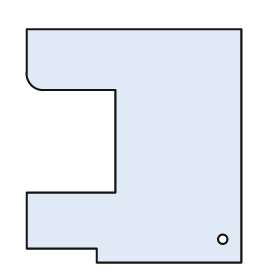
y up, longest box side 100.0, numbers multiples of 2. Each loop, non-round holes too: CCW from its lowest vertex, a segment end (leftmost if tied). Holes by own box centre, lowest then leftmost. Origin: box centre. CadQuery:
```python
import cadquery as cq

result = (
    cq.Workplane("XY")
    .moveTo(-16.0, -50.0)
    .lineTo(46.0, -50.0)
    .lineTo(46.0, 50.0)
    .lineTo(-46.0, 50.0)
    .lineTo(-46.0, 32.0)
    .threePointArc((-44.0, 26.0), (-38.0, 24.0))
    .lineTo(-8.0, 24.0)
    .lineTo(-8.0, -20.0)
    .lineTo(-46.0, -20.0)
    .lineTo(-46.0, -44.0)
    .lineTo(-16.0, -44.0)
    .close()
    .moveTo(38.0, -40.0)
    .circle(2.0)
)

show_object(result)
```